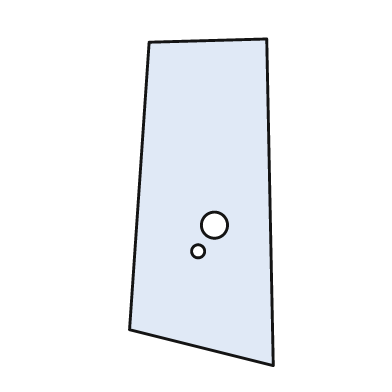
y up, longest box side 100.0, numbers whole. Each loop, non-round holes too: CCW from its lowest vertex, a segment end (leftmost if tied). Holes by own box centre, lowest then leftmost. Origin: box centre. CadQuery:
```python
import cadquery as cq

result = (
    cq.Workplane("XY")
    .moveTo(22.0, -50.0)
    .lineTo(20.0, 50.0)
    .lineTo(-16.0, 49.0)
    .lineTo(-22.0, -39.0)
    .close()
    .moveTo(-1.0, -15.0)
    .circle(2.0)
    .moveTo(4.0, -7.0)
    .circle(4.0)
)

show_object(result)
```